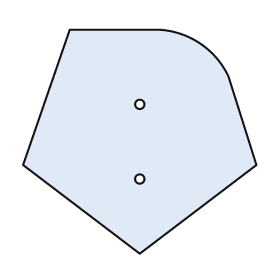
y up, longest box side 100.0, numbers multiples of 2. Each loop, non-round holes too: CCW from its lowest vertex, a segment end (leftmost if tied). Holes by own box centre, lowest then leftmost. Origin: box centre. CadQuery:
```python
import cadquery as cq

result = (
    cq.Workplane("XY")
    .moveTo(0.0, -48.0)
    .lineTo(50.0, -10.0)
    .lineTo(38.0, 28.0)
    .threePointArc((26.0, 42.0), (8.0, 48.0))
    .lineTo(-30.0, 48.0)
    .lineTo(-50.0, -10.0)
    .close()
    .moveTo(0.0, -16.0)
    .circle(2.0)
    .moveTo(0.0, 16.0)
    .circle(2.0)
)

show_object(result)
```